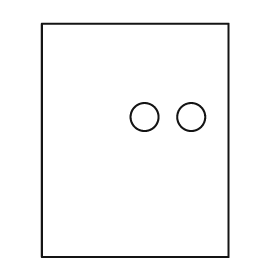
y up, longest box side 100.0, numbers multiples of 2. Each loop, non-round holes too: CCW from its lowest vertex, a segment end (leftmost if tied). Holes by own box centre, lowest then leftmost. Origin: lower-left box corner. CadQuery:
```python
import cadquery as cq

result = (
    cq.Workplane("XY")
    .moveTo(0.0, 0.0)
    .lineTo(80.0, 0.0)
    .lineTo(80.0, 100.0)
    .lineTo(0.0, 100.0)
    .close()
    .moveTo(44.0, 60.0)
    .circle(6.0)
    .moveTo(64.0, 60.0)
    .circle(6.0)
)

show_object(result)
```